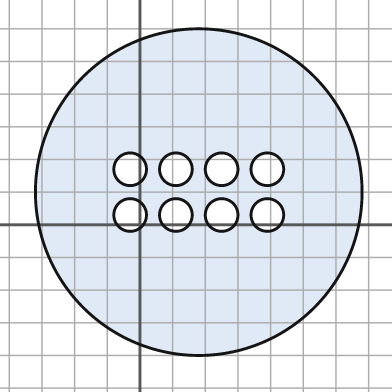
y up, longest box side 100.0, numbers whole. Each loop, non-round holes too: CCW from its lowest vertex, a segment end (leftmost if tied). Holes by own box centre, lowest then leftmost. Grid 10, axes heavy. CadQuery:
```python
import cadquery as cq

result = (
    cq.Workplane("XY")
    .moveTo(18.0, 10.0)
    .circle(50.0)
    .moveTo(-3.0, 3.0)
    .circle(5.0)
    .moveTo(11.0, 3.0)
    .circle(5.0)
    .moveTo(25.0, 3.0)
    .circle(5.0)
    .moveTo(39.0, 3.0)
    .circle(5.0)
    .moveTo(-3.0, 17.0)
    .circle(5.0)
    .moveTo(11.0, 17.0)
    .circle(5.0)
    .moveTo(25.0, 17.0)
    .circle(5.0)
    .moveTo(39.0, 17.0)
    .circle(5.0)
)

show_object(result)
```